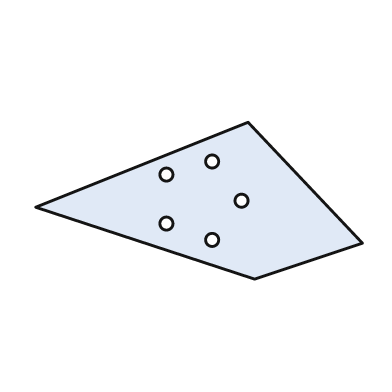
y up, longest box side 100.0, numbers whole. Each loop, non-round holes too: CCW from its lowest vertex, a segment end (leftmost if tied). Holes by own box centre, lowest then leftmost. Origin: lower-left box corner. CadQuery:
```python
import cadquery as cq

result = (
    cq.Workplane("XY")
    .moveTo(67.0, 0.0)
    .lineTo(100.0, 11.0)
    .lineTo(65.0, 48.0)
    .lineTo(0.0, 22.0)
    .close()
    .moveTo(54.0, 12.0)
    .circle(2.0)
    .moveTo(40.0, 17.0)
    .circle(2.0)
    .moveTo(63.0, 24.0)
    .circle(2.0)
    .moveTo(40.0, 32.0)
    .circle(2.0)
    .moveTo(54.0, 36.0)
    .circle(2.0)
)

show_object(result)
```